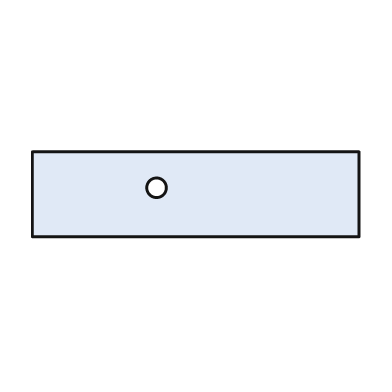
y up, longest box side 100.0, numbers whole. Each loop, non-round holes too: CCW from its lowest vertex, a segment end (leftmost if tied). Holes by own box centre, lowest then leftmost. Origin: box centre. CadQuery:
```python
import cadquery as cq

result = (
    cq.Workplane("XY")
    .moveTo(-50.0, -13.0)
    .lineTo(50.0, -13.0)
    .lineTo(50.0, 13.0)
    .lineTo(-50.0, 13.0)
    .close()
    .moveTo(-12.0, 2.0)
    .circle(3.0)
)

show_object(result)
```